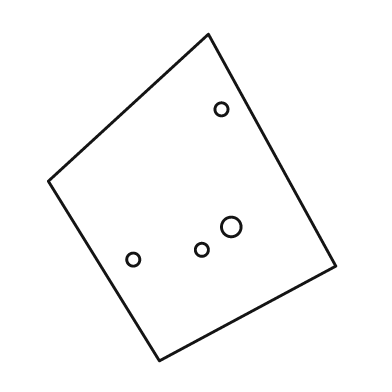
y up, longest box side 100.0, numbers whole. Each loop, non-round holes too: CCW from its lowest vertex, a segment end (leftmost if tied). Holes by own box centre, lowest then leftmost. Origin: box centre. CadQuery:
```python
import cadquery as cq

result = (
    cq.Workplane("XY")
    .moveTo(-10.0, -50.0)
    .lineTo(44.0, -21.0)
    .lineTo(5.0, 50.0)
    .lineTo(-44.0, 5.0)
    .close()
    .moveTo(-18.0, -19.0)
    .circle(2.0)
    .moveTo(3.0, -16.0)
    .circle(2.0)
    .moveTo(12.0, -9.0)
    .circle(3.0)
    .moveTo(9.0, 27.0)
    .circle(2.0)
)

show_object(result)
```